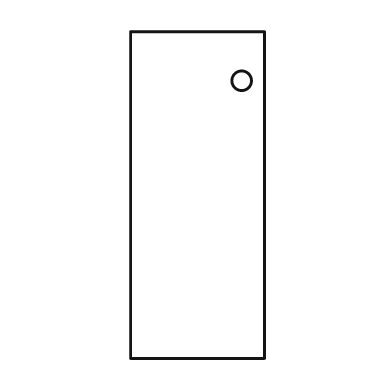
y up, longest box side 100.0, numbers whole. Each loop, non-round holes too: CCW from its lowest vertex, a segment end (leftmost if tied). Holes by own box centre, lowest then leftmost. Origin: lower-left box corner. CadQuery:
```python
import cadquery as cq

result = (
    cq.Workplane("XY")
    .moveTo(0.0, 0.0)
    .lineTo(41.0, 0.0)
    .lineTo(41.0, 100.0)
    .lineTo(0.0, 100.0)
    .close()
    .moveTo(34.0, 85.0)
    .circle(3.0)
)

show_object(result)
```